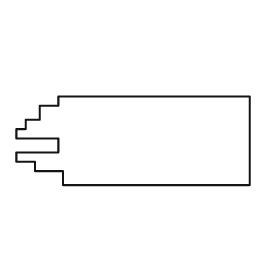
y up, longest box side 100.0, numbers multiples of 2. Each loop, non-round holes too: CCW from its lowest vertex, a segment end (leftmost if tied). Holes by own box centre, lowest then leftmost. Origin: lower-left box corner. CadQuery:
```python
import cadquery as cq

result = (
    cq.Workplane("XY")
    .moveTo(20.0, 0.0)
    .lineTo(100.0, 0.0)
    .lineTo(100.0, 38.0)
    .lineTo(18.0, 38.0)
    .lineTo(18.0, 34.0)
    .lineTo(10.0, 34.0)
    .lineTo(10.0, 28.0)
    .lineTo(4.0, 28.0)
    .lineTo(4.0, 24.0)
    .lineTo(0.0, 24.0)
    .lineTo(0.0, 20.0)
    .lineTo(18.0, 20.0)
    .lineTo(18.0, 14.0)
    .lineTo(0.0, 14.0)
    .lineTo(0.0, 10.0)
    .lineTo(8.0, 10.0)
    .lineTo(8.0, 6.0)
    .lineTo(20.0, 6.0)
    .close()
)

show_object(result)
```